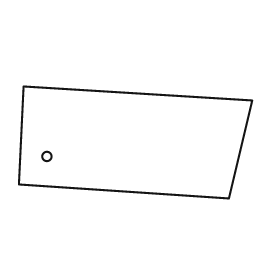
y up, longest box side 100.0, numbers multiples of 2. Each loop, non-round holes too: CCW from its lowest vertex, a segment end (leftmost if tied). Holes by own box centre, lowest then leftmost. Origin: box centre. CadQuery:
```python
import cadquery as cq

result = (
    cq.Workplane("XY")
    .moveTo(40.0, -24.0)
    .lineTo(50.0, 18.0)
    .lineTo(-48.0, 24.0)
    .lineTo(-50.0, -18.0)
    .close()
    .moveTo(-38.0, -6.0)
    .circle(2.0)
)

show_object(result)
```